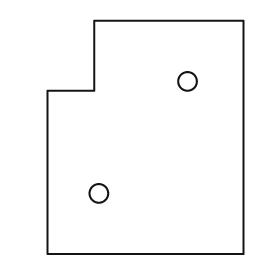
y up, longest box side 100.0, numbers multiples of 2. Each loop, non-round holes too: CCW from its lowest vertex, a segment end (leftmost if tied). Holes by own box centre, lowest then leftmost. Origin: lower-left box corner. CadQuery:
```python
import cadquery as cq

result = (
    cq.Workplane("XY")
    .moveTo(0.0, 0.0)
    .lineTo(84.0, 0.0)
    .lineTo(84.0, 100.0)
    .lineTo(20.0, 100.0)
    .lineTo(20.0, 70.0)
    .lineTo(0.0, 70.0)
    .close()
    .moveTo(22.0, 26.0)
    .circle(4.0)
    .moveTo(60.0, 74.0)
    .circle(4.0)
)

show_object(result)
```